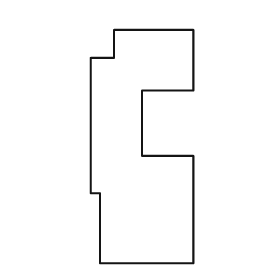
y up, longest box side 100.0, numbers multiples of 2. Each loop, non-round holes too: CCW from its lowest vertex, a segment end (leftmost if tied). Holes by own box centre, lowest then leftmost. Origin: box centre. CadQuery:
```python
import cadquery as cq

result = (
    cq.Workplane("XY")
    .moveTo(-18.0, -50.0)
    .lineTo(22.0, -50.0)
    .lineTo(22.0, -4.0)
    .lineTo(0.0, -4.0)
    .lineTo(0.0, 24.0)
    .lineTo(22.0, 24.0)
    .lineTo(22.0, 50.0)
    .lineTo(-12.0, 50.0)
    .lineTo(-12.0, 38.0)
    .lineTo(-22.0, 38.0)
    .lineTo(-22.0, -20.0)
    .lineTo(-18.0, -20.0)
    .close()
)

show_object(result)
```